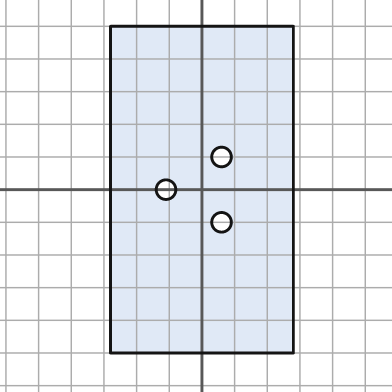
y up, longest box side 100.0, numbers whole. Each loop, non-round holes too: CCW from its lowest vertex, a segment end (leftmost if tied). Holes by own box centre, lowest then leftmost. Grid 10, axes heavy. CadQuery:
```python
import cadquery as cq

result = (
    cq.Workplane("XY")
    .moveTo(-28.0, -50.0)
    .lineTo(28.0, -50.0)
    .lineTo(28.0, 50.0)
    .lineTo(-28.0, 50.0)
    .close()
    .moveTo(6.0, -10.0)
    .circle(3.0)
    .moveTo(-11.0, 0.0)
    .circle(3.0)
    .moveTo(6.0, 10.0)
    .circle(3.0)
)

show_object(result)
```